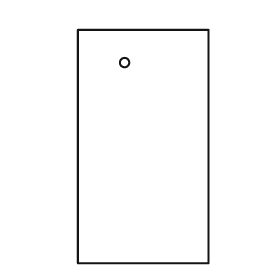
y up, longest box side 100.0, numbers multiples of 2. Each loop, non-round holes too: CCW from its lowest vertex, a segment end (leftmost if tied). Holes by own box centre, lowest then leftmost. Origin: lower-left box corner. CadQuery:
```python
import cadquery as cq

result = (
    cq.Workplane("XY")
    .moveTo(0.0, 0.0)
    .lineTo(56.0, 0.0)
    .lineTo(56.0, 100.0)
    .lineTo(0.0, 100.0)
    .close()
    .moveTo(20.0, 86.0)
    .circle(2.0)
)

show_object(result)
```